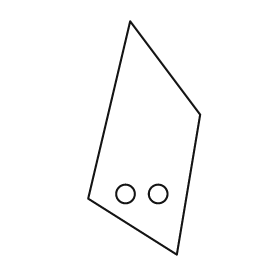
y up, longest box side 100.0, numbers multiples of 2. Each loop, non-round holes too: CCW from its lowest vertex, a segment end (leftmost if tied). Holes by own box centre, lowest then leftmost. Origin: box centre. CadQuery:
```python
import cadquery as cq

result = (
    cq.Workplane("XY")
    .moveTo(14.0, -50.0)
    .lineTo(24.0, 10.0)
    .lineTo(-6.0, 50.0)
    .lineTo(-24.0, -26.0)
    .close()
    .moveTo(-8.0, -24.0)
    .circle(4.0)
    .moveTo(6.0, -24.0)
    .circle(4.0)
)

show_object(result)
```